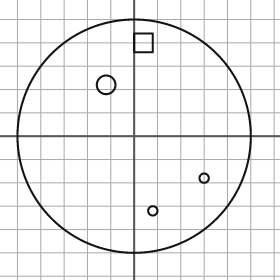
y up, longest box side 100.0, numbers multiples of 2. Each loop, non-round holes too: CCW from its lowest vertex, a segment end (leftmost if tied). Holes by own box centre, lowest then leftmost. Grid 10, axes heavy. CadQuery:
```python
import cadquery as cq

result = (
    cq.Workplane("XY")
    .moveTo(0.0, 0.0)
    .circle(50.0)
    .moveTo(8.0, -32.0)
    .circle(2.0)
    .moveTo(30.0, -18.0)
    .circle(2.0)
    .moveTo(-12.0, 22.0)
    .circle(4.0)
    .moveTo(0.0, 36.0)
    .lineTo(8.0, 36.0)
    .lineTo(8.0, 44.0)
    .lineTo(0.0, 44.0)
    .close()
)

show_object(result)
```